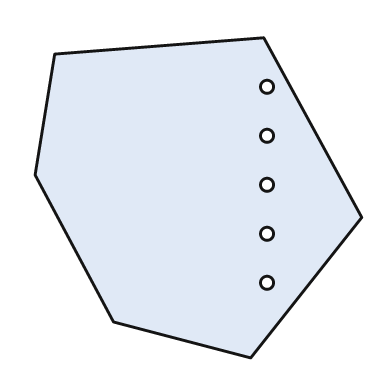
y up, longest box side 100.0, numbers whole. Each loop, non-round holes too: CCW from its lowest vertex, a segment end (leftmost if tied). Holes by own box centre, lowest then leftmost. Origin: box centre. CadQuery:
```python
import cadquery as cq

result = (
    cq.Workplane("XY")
    .moveTo(16.0, -49.0)
    .lineTo(50.0, -6.0)
    .lineTo(20.0, 49.0)
    .lineTo(-44.0, 44.0)
    .lineTo(-50.0, 7.0)
    .lineTo(-26.0, -38.0)
    .close()
    .moveTo(21.0, -26.0)
    .circle(2.0)
    .moveTo(21.0, -11.0)
    .circle(2.0)
    .moveTo(21.0, 4.0)
    .circle(2.0)
    .moveTo(21.0, 19.0)
    .circle(2.0)
    .moveTo(21.0, 34.0)
    .circle(2.0)
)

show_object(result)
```